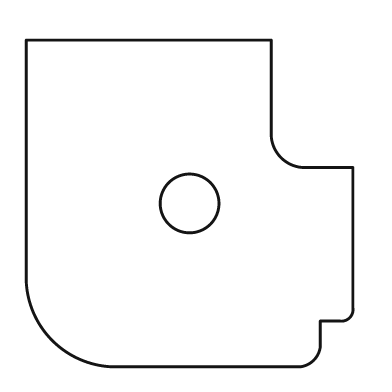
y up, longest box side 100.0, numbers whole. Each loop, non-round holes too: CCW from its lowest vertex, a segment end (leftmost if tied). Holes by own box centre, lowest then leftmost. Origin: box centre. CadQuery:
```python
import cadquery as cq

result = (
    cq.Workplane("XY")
    .moveTo(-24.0, -50.0)
    .lineTo(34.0, -50.0)
    .threePointArc((38.0, -48.0), (40.0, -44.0))
    .lineTo(40.0, -36.0)
    .lineTo(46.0, -36.0)
    .threePointArc((49.0, -35.0), (50.0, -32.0))
    .lineTo(50.0, 11.0)
    .lineTo(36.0, 11.0)
    .threePointArc((28.0, 14.0), (25.0, 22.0))
    .lineTo(25.0, 50.0)
    .lineTo(-50.0, 50.0)
    .lineTo(-50.0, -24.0)
    .threePointArc((-42.0, -42.0), (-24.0, -50.0))
    .close()
    .moveTo(0.0, 0.0)
    .circle(9.0)
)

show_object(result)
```